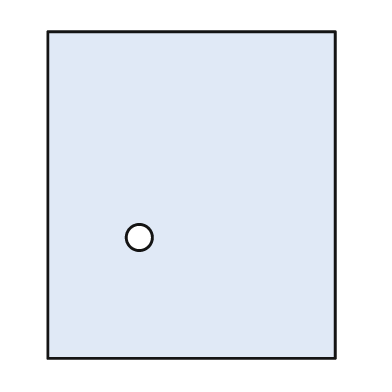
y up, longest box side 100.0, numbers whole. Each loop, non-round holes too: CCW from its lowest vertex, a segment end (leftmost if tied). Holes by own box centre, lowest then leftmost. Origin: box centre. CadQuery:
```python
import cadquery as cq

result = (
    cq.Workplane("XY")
    .moveTo(-44.0, -50.0)
    .lineTo(44.0, -50.0)
    .lineTo(44.0, 50.0)
    .lineTo(-44.0, 50.0)
    .close()
    .moveTo(-16.0, -13.0)
    .circle(4.0)
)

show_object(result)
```